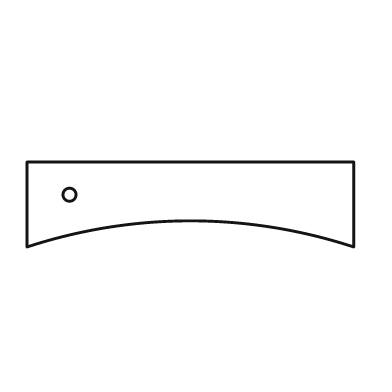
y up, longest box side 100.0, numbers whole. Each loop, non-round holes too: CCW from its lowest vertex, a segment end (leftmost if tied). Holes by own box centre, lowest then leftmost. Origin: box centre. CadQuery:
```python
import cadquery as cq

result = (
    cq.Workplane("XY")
    .moveTo(-50.0, -13.0)
    .threePointArc((0.0, -5.0), (50.0, -13.0))
    .lineTo(50.0, 13.0)
    .lineTo(-50.0, 13.0)
    .close()
    .moveTo(-37.0, 3.0)
    .circle(2.0)
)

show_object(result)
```